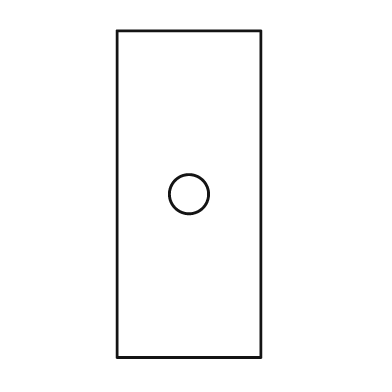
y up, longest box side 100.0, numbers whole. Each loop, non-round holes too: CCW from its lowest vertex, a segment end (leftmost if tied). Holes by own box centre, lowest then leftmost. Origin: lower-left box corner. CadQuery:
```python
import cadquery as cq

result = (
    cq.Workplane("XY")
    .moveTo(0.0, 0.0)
    .lineTo(44.0, 0.0)
    .lineTo(44.0, 100.0)
    .lineTo(0.0, 100.0)
    .close()
    .moveTo(22.0, 50.0)
    .circle(6.0)
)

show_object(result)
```